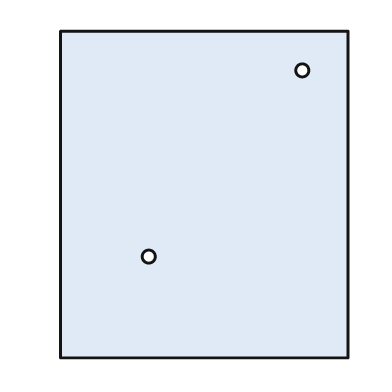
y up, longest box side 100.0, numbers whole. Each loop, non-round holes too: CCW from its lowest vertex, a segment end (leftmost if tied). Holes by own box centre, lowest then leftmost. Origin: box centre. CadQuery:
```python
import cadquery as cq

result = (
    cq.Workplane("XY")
    .moveTo(-44.0, -50.0)
    .lineTo(44.0, -50.0)
    .lineTo(44.0, 50.0)
    .lineTo(-44.0, 50.0)
    .close()
    .moveTo(-17.0, -19.0)
    .circle(2.0)
    .moveTo(30.0, 38.0)
    .circle(2.0)
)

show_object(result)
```